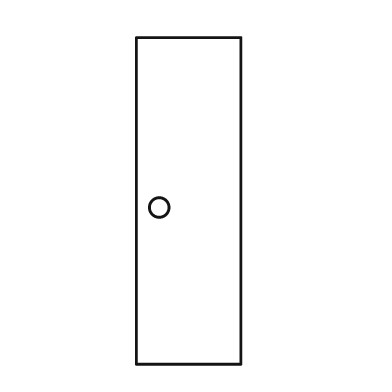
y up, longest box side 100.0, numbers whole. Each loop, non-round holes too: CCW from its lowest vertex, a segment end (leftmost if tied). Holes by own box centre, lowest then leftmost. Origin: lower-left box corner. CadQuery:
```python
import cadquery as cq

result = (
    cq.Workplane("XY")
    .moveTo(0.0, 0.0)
    .lineTo(32.0, 0.0)
    .lineTo(32.0, 100.0)
    .lineTo(0.0, 100.0)
    .close()
    .moveTo(7.0, 48.0)
    .circle(3.0)
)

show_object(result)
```